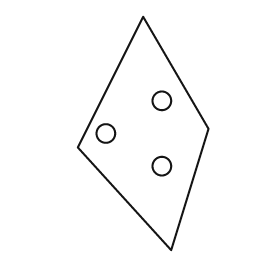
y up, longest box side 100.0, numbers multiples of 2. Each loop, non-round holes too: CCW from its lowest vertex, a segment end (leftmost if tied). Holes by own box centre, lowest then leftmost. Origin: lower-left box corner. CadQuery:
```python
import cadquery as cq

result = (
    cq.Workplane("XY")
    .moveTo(40.0, 0.0)
    .lineTo(56.0, 52.0)
    .lineTo(28.0, 100.0)
    .lineTo(0.0, 44.0)
    .close()
    .moveTo(36.0, 36.0)
    .circle(4.0)
    .moveTo(12.0, 50.0)
    .circle(4.0)
    .moveTo(36.0, 64.0)
    .circle(4.0)
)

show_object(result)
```